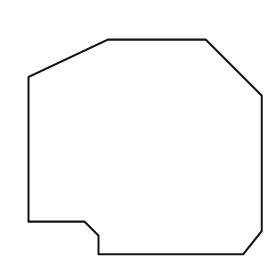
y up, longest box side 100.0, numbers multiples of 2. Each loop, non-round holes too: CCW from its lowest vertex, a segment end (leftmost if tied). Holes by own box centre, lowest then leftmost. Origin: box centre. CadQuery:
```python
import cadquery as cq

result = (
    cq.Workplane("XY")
    .moveTo(-20.0, -46.0)
    .lineTo(42.0, -46.0)
    .lineTo(50.0, -36.0)
    .lineTo(50.0, 22.0)
    .lineTo(26.0, 46.0)
    .lineTo(-16.0, 46.0)
    .lineTo(-50.0, 30.0)
    .lineTo(-50.0, -32.0)
    .lineTo(-26.0, -32.0)
    .lineTo(-20.0, -38.0)
    .close()
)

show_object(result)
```